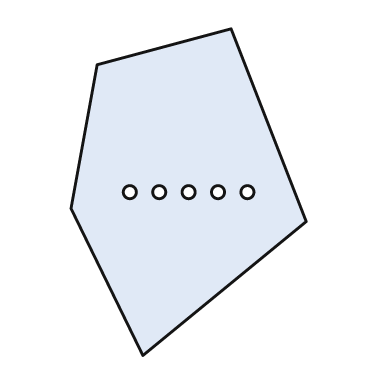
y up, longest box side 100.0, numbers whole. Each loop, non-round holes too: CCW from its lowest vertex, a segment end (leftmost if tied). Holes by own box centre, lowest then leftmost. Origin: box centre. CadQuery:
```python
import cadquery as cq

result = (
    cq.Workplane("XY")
    .moveTo(-14.0, -50.0)
    .lineTo(36.0, -9.0)
    .lineTo(13.0, 50.0)
    .lineTo(-28.0, 39.0)
    .lineTo(-36.0, -5.0)
    .close()
    .moveTo(-18.0, 0.0)
    .circle(2.0)
    .moveTo(-9.0, 0.0)
    .circle(2.0)
    .moveTo(0.0, 0.0)
    .circle(2.0)
    .moveTo(9.0, 0.0)
    .circle(2.0)
    .moveTo(18.0, 0.0)
    .circle(2.0)
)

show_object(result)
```